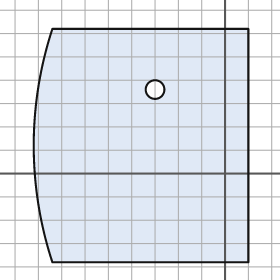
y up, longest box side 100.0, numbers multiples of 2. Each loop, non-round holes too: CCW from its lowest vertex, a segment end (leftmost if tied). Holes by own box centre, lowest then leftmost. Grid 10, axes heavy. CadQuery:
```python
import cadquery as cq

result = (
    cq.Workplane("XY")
    .moveTo(-74.0, -38.0)
    .lineTo(10.0, -38.0)
    .lineTo(10.0, 62.0)
    .lineTo(-74.0, 62.0)
    .threePointArc((-82.0, 12.0), (-74.0, -38.0))
    .close()
    .moveTo(-30.0, 36.0)
    .circle(4.0)
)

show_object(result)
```